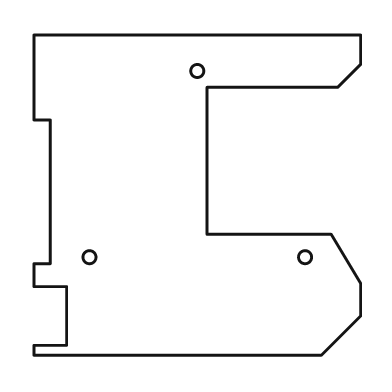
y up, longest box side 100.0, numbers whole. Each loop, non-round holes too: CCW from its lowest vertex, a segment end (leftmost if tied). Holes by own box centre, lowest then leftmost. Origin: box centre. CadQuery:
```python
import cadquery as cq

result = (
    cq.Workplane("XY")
    .moveTo(-50.0, -49.0)
    .lineTo(38.0, -49.0)
    .lineTo(50.0, -37.0)
    .lineTo(50.0, -27.0)
    .lineTo(41.0, -12.0)
    .lineTo(3.0, -12.0)
    .lineTo(3.0, 33.0)
    .lineTo(43.0, 33.0)
    .lineTo(50.0, 40.0)
    .lineTo(50.0, 49.0)
    .lineTo(-50.0, 49.0)
    .lineTo(-50.0, 23.0)
    .lineTo(-45.0, 23.0)
    .lineTo(-45.0, -21.0)
    .lineTo(-50.0, -21.0)
    .lineTo(-50.0, -28.0)
    .lineTo(-40.0, -28.0)
    .lineTo(-40.0, -46.0)
    .lineTo(-50.0, -46.0)
    .close()
    .moveTo(-33.0, -19.0)
    .circle(2.0)
    .moveTo(33.0, -19.0)
    .circle(2.0)
    .moveTo(0.0, 38.0)
    .circle(2.0)
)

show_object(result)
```